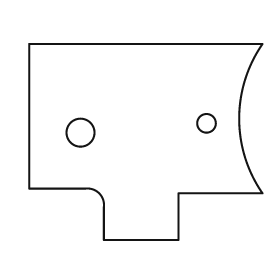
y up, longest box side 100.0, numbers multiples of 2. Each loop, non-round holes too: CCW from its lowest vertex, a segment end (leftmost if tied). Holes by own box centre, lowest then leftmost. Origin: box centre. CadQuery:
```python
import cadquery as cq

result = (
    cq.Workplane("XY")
    .moveTo(-18.0, -42.0)
    .lineTo(14.0, -42.0)
    .lineTo(14.0, -22.0)
    .lineTo(50.0, -22.0)
    .threePointArc((40.0, 10.0), (50.0, 42.0))
    .lineTo(-50.0, 42.0)
    .lineTo(-50.0, -20.0)
    .lineTo(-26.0, -20.0)
    .threePointArc((-20.0, -22.0), (-18.0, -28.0))
    .close()
    .moveTo(-28.0, 4.0)
    .circle(6.0)
    .moveTo(26.0, 8.0)
    .circle(4.0)
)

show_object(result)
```